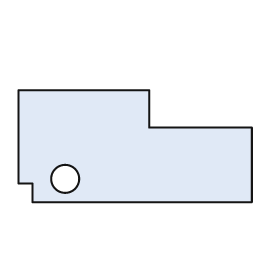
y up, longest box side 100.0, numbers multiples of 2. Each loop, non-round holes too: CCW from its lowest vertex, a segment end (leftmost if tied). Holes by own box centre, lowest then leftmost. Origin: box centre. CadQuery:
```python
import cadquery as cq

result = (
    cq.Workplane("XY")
    .moveTo(-44.0, -24.0)
    .lineTo(50.0, -24.0)
    .lineTo(50.0, 8.0)
    .lineTo(6.0, 8.0)
    .lineTo(6.0, 24.0)
    .lineTo(-50.0, 24.0)
    .lineTo(-50.0, -16.0)
    .lineTo(-44.0, -16.0)
    .close()
    .moveTo(-30.0, -14.0)
    .circle(6.0)
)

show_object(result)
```